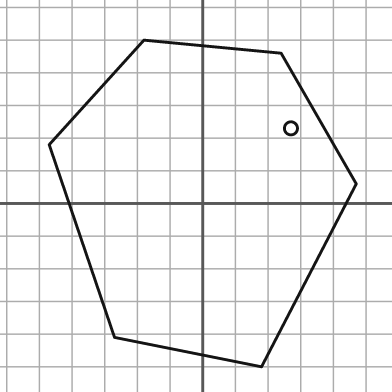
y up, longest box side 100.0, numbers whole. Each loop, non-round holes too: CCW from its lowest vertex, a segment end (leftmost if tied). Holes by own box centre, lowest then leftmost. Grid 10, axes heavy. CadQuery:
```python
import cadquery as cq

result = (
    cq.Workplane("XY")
    .moveTo(18.0, -50.0)
    .lineTo(47.0, 6.0)
    .lineTo(24.0, 46.0)
    .lineTo(-18.0, 50.0)
    .lineTo(-47.0, 18.0)
    .lineTo(-27.0, -41.0)
    .close()
    .moveTo(27.0, 23.0)
    .circle(2.0)
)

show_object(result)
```